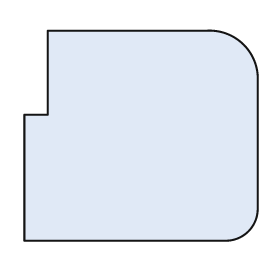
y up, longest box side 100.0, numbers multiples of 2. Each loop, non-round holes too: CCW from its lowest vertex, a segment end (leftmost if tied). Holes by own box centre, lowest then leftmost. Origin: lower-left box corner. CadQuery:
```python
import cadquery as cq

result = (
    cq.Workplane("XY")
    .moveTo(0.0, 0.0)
    .lineTo(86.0, 0.0)
    .threePointArc((96.0, 4.0), (100.0, 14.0))
    .lineTo(100.0, 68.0)
    .threePointArc((94.0, 84.0), (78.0, 90.0))
    .lineTo(10.0, 90.0)
    .lineTo(10.0, 54.0)
    .lineTo(0.0, 54.0)
    .close()
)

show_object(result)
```